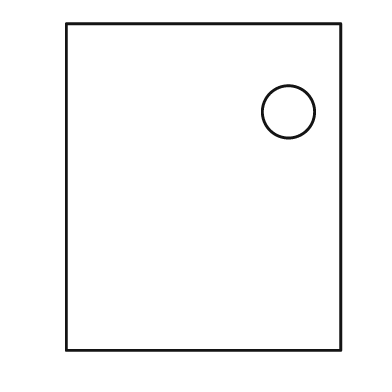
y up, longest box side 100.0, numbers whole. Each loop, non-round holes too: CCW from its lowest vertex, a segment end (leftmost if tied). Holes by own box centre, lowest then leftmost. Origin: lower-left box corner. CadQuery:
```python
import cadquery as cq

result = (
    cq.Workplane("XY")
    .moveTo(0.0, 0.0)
    .lineTo(84.0, 0.0)
    .lineTo(84.0, 100.0)
    .lineTo(0.0, 100.0)
    .close()
    .moveTo(68.0, 73.0)
    .circle(8.0)
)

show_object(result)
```